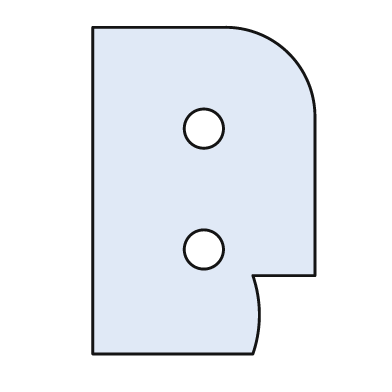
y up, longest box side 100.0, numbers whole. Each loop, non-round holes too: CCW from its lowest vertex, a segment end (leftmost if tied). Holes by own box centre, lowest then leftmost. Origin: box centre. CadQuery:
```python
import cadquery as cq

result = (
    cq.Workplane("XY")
    .moveTo(-34.0, -50.0)
    .lineTo(15.0, -50.0)
    .threePointArc((17.0, -38.0), (15.0, -26.0))
    .lineTo(34.0, -26.0)
    .lineTo(34.0, 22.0)
    .threePointArc((26.0, 42.0), (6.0, 50.0))
    .lineTo(-34.0, 50.0)
    .close()
    .moveTo(0.0, -18.0)
    .circle(6.0)
    .moveTo(0.0, 19.0)
    .circle(6.0)
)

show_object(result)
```